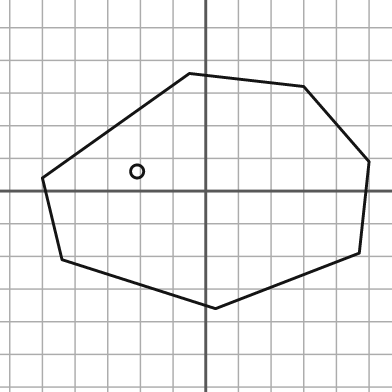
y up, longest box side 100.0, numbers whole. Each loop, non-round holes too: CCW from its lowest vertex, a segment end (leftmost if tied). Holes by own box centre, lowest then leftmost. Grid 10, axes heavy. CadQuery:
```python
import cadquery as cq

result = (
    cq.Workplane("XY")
    .moveTo(3.0, -36.0)
    .lineTo(47.0, -19.0)
    .lineTo(50.0, 9.0)
    .lineTo(30.0, 32.0)
    .lineTo(-5.0, 36.0)
    .lineTo(-50.0, 4.0)
    .lineTo(-44.0, -21.0)
    .close()
    .moveTo(-21.0, 6.0)
    .circle(2.0)
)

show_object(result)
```